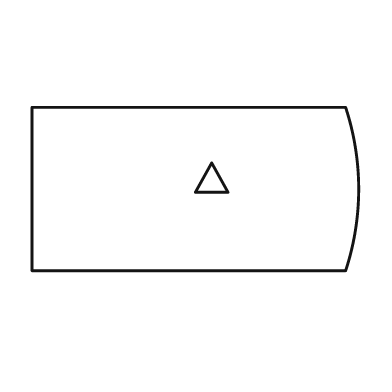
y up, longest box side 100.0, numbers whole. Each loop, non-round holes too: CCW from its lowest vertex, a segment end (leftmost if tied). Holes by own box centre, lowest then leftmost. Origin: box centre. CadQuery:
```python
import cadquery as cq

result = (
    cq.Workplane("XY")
    .moveTo(-50.0, -25.0)
    .lineTo(46.0, -25.0)
    .threePointArc((50.0, 0.0), (46.0, 25.0))
    .lineTo(-50.0, 25.0)
    .close()
    .moveTo(0.0, -1.0)
    .lineTo(10.0, -1.0)
    .lineTo(5.0, 8.0)
    .close()
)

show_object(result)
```